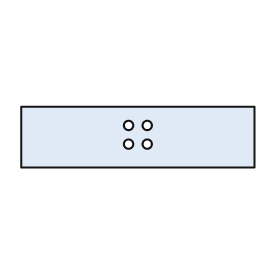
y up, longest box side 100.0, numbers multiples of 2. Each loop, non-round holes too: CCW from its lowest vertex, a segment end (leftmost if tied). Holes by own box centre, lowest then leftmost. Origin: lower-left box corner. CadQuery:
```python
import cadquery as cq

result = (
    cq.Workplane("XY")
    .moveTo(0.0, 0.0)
    .lineTo(100.0, 0.0)
    .lineTo(100.0, 26.0)
    .lineTo(0.0, 26.0)
    .close()
    .moveTo(46.0, 10.0)
    .circle(2.0)
    .moveTo(54.0, 10.0)
    .circle(2.0)
    .moveTo(46.0, 18.0)
    .circle(2.0)
    .moveTo(54.0, 18.0)
    .circle(2.0)
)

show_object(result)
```